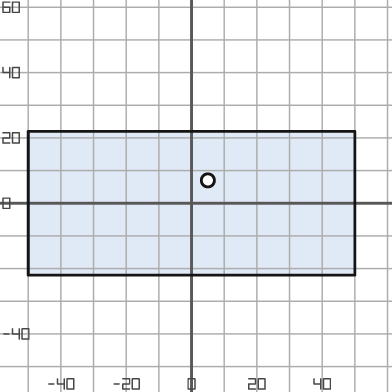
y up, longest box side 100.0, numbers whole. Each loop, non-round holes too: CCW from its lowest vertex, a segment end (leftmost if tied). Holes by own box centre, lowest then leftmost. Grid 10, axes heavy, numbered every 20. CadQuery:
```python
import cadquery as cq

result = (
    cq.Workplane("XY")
    .moveTo(-50.0, -22.0)
    .lineTo(50.0, -22.0)
    .lineTo(50.0, 22.0)
    .lineTo(-50.0, 22.0)
    .close()
    .moveTo(5.0, 7.0)
    .circle(2.0)
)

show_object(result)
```